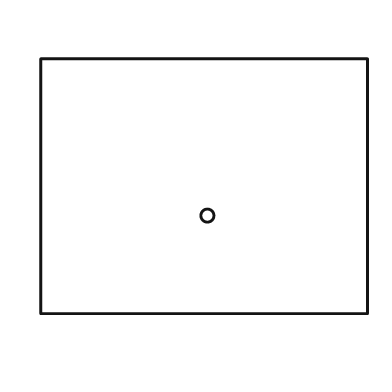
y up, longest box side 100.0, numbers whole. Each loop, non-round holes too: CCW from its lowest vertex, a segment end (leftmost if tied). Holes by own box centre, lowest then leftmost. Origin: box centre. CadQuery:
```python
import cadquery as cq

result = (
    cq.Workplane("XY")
    .moveTo(-50.0, -39.0)
    .lineTo(50.0, -39.0)
    .lineTo(50.0, 39.0)
    .lineTo(-50.0, 39.0)
    .close()
    .moveTo(1.0, -9.0)
    .circle(2.0)
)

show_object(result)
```